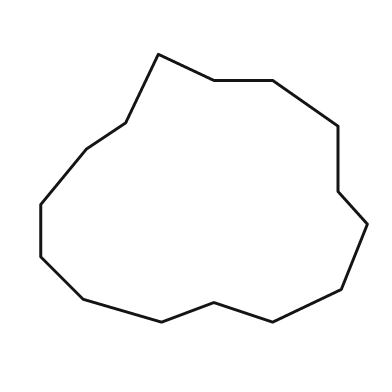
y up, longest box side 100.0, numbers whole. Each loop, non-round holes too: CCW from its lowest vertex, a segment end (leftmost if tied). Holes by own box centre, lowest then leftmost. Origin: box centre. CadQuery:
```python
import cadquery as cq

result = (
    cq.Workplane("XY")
    .moveTo(-13.0, -41.0)
    .lineTo(3.0, -35.0)
    .lineTo(21.0, -41.0)
    .lineTo(42.0, -31.0)
    .lineTo(50.0, -11.0)
    .lineTo(41.0, -1.0)
    .lineTo(41.0, 19.0)
    .lineTo(21.0, 33.0)
    .lineTo(3.0, 33.0)
    .lineTo(-14.0, 41.0)
    .lineTo(-24.0, 20.0)
    .lineTo(-36.0, 12.0)
    .lineTo(-50.0, -5.0)
    .lineTo(-50.0, -21.0)
    .lineTo(-37.0, -34.0)
    .close()
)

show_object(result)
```